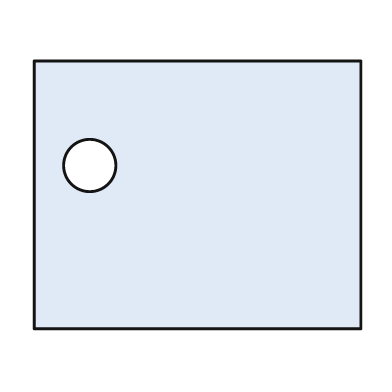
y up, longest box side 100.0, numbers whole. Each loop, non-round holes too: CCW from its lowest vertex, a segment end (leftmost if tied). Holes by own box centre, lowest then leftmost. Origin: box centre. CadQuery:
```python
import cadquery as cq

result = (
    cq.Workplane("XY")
    .moveTo(-50.0, -41.0)
    .lineTo(50.0, -41.0)
    .lineTo(50.0, 41.0)
    .lineTo(-50.0, 41.0)
    .close()
    .moveTo(-33.0, 9.0)
    .circle(8.0)
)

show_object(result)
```